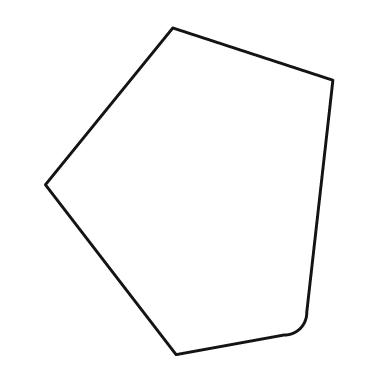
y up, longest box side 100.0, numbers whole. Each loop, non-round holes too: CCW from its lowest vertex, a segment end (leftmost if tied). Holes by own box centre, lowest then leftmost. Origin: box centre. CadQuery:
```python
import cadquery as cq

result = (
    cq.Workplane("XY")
    .moveTo(-4.0, -50.0)
    .lineTo(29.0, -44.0)
    .threePointArc((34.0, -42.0), (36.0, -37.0))
    .lineTo(44.0, 34.0)
    .lineTo(-5.0, 50.0)
    .lineTo(-44.0, 2.0)
    .close()
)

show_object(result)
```